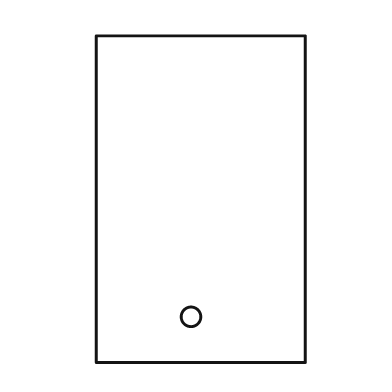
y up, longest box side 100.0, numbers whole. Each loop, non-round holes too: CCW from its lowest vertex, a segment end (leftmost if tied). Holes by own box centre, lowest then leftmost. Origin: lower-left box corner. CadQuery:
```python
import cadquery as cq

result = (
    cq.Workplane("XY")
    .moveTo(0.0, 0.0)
    .lineTo(64.0, 0.0)
    .lineTo(64.0, 100.0)
    .lineTo(0.0, 100.0)
    .close()
    .moveTo(29.0, 14.0)
    .circle(3.0)
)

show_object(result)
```